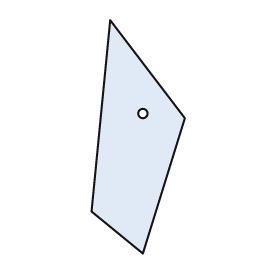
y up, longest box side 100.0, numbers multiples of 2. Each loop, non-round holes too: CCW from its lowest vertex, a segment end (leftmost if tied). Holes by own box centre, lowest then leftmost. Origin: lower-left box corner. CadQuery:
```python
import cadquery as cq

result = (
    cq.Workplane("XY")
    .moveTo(22.0, 0.0)
    .lineTo(40.0, 58.0)
    .lineTo(8.0, 100.0)
    .lineTo(0.0, 18.0)
    .close()
    .moveTo(22.0, 60.0)
    .circle(2.0)
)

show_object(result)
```